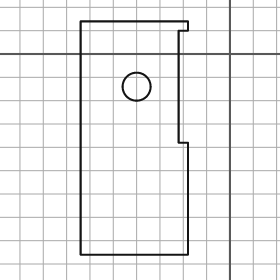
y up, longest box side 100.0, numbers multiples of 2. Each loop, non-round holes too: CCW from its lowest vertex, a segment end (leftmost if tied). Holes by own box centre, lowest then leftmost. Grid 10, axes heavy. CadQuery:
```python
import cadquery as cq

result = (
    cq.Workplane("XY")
    .moveTo(-64.0, -86.0)
    .lineTo(-18.0, -86.0)
    .lineTo(-18.0, -38.0)
    .lineTo(-22.0, -38.0)
    .lineTo(-22.0, 10.0)
    .lineTo(-18.0, 10.0)
    .lineTo(-18.0, 14.0)
    .lineTo(-64.0, 14.0)
    .close()
    .moveTo(-40.0, -14.0)
    .circle(6.0)
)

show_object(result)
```